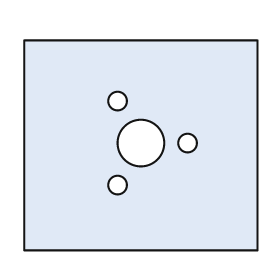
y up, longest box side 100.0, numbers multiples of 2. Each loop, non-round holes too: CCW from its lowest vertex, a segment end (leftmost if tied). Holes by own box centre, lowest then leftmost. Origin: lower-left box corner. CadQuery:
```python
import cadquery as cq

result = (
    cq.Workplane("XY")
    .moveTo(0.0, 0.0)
    .lineTo(100.0, 0.0)
    .lineTo(100.0, 90.0)
    .lineTo(0.0, 90.0)
    .close()
    .moveTo(40.0, 28.0)
    .circle(4.0)
    .moveTo(50.0, 46.0)
    .circle(10.0)
    .moveTo(70.0, 46.0)
    .circle(4.0)
    .moveTo(40.0, 64.0)
    .circle(4.0)
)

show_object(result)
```